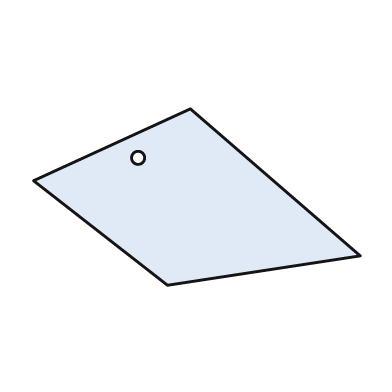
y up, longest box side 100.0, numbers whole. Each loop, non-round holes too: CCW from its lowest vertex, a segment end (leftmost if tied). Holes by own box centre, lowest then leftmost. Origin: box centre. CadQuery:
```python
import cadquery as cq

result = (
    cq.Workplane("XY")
    .moveTo(-9.0, -27.0)
    .lineTo(50.0, -18.0)
    .lineTo(-2.0, 27.0)
    .lineTo(-50.0, 5.0)
    .close()
    .moveTo(-18.0, 12.0)
    .circle(2.0)
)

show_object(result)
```